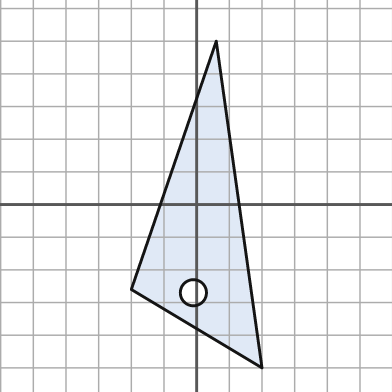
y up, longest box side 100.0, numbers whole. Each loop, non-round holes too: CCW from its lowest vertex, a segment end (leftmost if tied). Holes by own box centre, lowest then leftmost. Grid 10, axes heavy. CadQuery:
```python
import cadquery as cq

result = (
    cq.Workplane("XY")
    .moveTo(20.0, -50.0)
    .lineTo(6.0, 50.0)
    .lineTo(-20.0, -26.0)
    .close()
    .moveTo(-1.0, -27.0)
    .circle(4.0)
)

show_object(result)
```